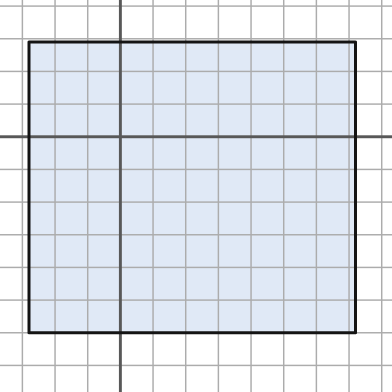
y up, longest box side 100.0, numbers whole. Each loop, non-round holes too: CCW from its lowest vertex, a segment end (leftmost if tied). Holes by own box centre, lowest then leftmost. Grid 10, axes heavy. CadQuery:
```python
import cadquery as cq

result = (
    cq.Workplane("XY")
    .moveTo(-28.0, -60.0)
    .lineTo(72.0, -60.0)
    .lineTo(72.0, 29.0)
    .lineTo(-28.0, 29.0)
    .close()
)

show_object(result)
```